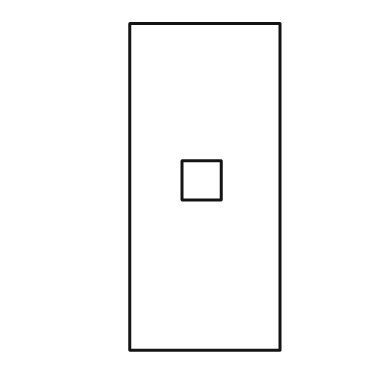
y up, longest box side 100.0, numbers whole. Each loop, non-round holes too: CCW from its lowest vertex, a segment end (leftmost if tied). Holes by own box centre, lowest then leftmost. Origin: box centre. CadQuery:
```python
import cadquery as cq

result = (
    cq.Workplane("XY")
    .moveTo(-23.0, -50.0)
    .lineTo(23.0, -50.0)
    .lineTo(23.0, 50.0)
    .lineTo(-23.0, 50.0)
    .close()
    .moveTo(-7.0, -4.0)
    .lineTo(5.0, -4.0)
    .lineTo(5.0, 8.0)
    .lineTo(-7.0, 8.0)
    .close()
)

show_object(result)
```